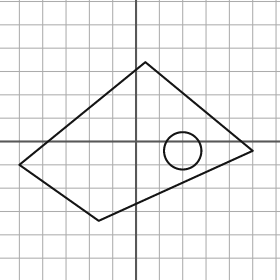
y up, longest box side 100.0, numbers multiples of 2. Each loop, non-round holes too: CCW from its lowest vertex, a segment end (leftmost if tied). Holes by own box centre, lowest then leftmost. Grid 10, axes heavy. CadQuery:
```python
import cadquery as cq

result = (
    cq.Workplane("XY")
    .moveTo(-16.0, -34.0)
    .lineTo(50.0, -4.0)
    .lineTo(4.0, 34.0)
    .lineTo(-50.0, -10.0)
    .close()
    .moveTo(20.0, -4.0)
    .circle(8.0)
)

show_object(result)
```